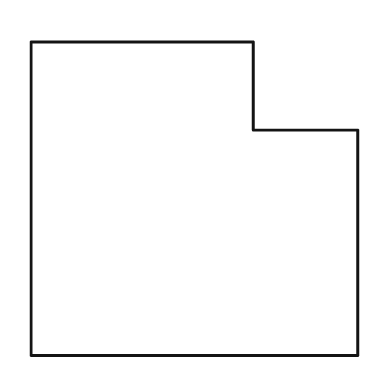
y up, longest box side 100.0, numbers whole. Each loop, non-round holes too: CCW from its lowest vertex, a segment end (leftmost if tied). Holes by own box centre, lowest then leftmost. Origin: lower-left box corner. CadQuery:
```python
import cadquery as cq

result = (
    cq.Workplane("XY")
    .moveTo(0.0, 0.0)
    .lineTo(100.0, 0.0)
    .lineTo(100.0, 69.0)
    .lineTo(68.0, 69.0)
    .lineTo(68.0, 96.0)
    .lineTo(0.0, 96.0)
    .close()
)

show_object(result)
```